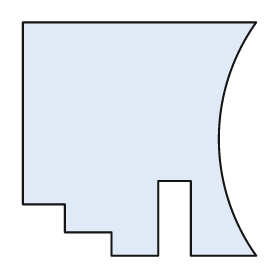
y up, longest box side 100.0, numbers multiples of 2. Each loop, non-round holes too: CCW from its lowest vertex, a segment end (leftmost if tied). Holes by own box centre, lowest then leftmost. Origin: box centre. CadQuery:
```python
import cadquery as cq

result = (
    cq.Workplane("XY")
    .moveTo(-12.0, -50.0)
    .lineTo(8.0, -50.0)
    .lineTo(8.0, -18.0)
    .lineTo(22.0, -18.0)
    .lineTo(22.0, -50.0)
    .lineTo(50.0, -50.0)
    .threePointArc((34.0, 0.0), (50.0, 50.0))
    .lineTo(-50.0, 50.0)
    .lineTo(-50.0, -28.0)
    .lineTo(-32.0, -28.0)
    .lineTo(-32.0, -40.0)
    .lineTo(-12.0, -40.0)
    .close()
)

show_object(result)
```